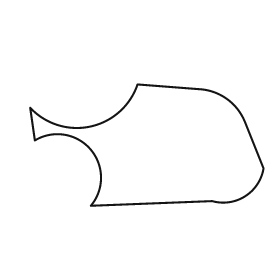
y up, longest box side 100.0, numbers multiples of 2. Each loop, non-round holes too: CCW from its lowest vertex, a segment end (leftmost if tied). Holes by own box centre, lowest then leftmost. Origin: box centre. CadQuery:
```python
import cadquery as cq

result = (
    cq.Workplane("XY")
    .moveTo(-24.0, -26.0)
    .lineTo(28.0, -24.0)
    .threePointArc((42.0, -22.0), (50.0, -10.0))
    .lineTo(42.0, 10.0)
    .threePointArc((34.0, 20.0), (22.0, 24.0))
    .lineTo(-4.0, 26.0)
    .threePointArc((-24.0, 8.0), (-50.0, 16.0))
    .lineTo(-48.0, 2.0)
    .threePointArc((-24.0, -2.0), (-24.0, -26.0))
    .close()
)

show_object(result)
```